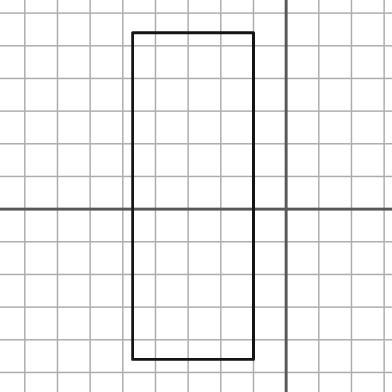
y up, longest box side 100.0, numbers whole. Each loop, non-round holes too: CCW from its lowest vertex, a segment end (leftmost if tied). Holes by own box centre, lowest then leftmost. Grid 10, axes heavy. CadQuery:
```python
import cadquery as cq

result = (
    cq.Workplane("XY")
    .moveTo(-47.0, -46.0)
    .lineTo(-10.0, -46.0)
    .lineTo(-10.0, 54.0)
    .lineTo(-47.0, 54.0)
    .close()
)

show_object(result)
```